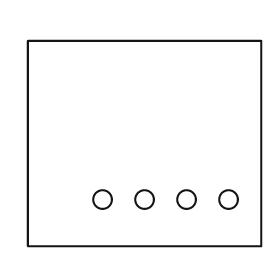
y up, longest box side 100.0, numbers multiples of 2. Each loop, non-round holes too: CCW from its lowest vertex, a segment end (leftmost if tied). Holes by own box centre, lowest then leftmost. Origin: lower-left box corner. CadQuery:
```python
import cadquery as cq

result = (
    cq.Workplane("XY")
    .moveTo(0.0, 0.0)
    .lineTo(100.0, 0.0)
    .lineTo(100.0, 88.0)
    .lineTo(0.0, 88.0)
    .close()
    .moveTo(32.0, 20.0)
    .circle(4.0)
    .moveTo(50.0, 20.0)
    .circle(4.0)
    .moveTo(68.0, 20.0)
    .circle(4.0)
    .moveTo(86.0, 20.0)
    .circle(4.0)
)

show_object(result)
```